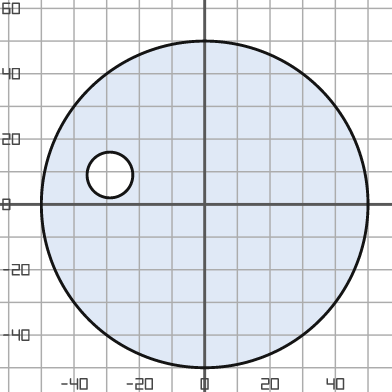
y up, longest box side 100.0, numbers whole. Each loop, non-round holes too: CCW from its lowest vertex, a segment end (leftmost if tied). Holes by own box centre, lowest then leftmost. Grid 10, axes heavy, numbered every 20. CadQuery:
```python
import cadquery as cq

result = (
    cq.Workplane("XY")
    .moveTo(0.0, 0.0)
    .circle(50.0)
    .moveTo(-29.0, 9.0)
    .circle(7.0)
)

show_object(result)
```